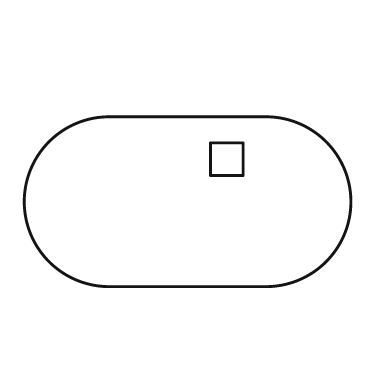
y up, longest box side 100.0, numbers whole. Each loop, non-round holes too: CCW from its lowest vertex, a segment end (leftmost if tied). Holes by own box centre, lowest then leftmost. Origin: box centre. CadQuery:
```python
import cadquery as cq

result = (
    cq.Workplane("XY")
    .moveTo(-24.0, -26.0)
    .lineTo(24.0, -26.0)
    .threePointArc((50.0, 0.0), (24.0, 26.0))
    .lineTo(-24.0, 26.0)
    .threePointArc((-50.0, 0.0), (-24.0, -26.0))
    .close()
    .moveTo(7.0, 8.0)
    .lineTo(17.0, 8.0)
    .lineTo(17.0, 18.0)
    .lineTo(7.0, 18.0)
    .close()
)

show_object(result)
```